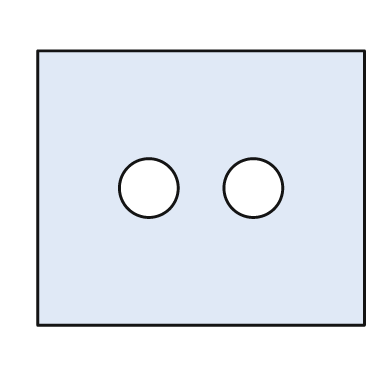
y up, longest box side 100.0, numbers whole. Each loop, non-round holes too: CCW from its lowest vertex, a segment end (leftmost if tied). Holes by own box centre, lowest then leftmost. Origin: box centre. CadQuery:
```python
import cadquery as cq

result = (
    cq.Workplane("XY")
    .moveTo(-50.0, -42.0)
    .lineTo(50.0, -42.0)
    .lineTo(50.0, 42.0)
    .lineTo(-50.0, 42.0)
    .close()
    .moveTo(-16.0, 0.0)
    .circle(9.0)
    .moveTo(16.0, 0.0)
    .circle(9.0)
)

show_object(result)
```